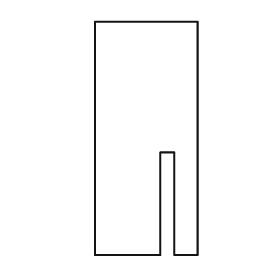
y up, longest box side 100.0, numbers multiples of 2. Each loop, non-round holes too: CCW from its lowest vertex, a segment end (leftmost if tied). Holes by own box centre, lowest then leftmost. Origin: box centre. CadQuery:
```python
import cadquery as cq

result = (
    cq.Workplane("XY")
    .moveTo(-22.0, -50.0)
    .lineTo(6.0, -50.0)
    .lineTo(6.0, -6.0)
    .lineTo(12.0, -6.0)
    .lineTo(12.0, -50.0)
    .lineTo(22.0, -50.0)
    .lineTo(22.0, 50.0)
    .lineTo(-22.0, 50.0)
    .close()
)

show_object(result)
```